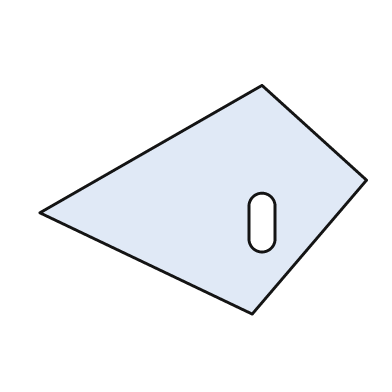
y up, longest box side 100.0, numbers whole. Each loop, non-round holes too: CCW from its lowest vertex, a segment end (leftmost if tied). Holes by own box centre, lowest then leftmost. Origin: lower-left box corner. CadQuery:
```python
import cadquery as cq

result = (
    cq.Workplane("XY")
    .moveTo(65.0, 0.0)
    .lineTo(100.0, 41.0)
    .lineTo(68.0, 70.0)
    .lineTo(0.0, 31.0)
    .close()
    .moveTo(64.0, 23.0)
    .threePointArc((68.0, 19.0), (72.0, 23.0))
    .lineTo(72.0, 33.0)
    .threePointArc((68.0, 37.0), (64.0, 33.0))
    .close()
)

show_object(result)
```